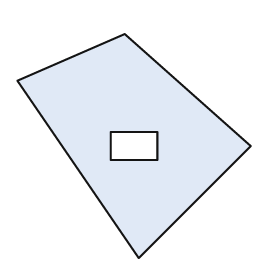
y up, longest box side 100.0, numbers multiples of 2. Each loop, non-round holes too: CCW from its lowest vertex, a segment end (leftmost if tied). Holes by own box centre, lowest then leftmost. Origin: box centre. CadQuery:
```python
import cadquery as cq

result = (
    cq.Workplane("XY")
    .moveTo(2.0, -48.0)
    .lineTo(50.0, 0.0)
    .lineTo(-4.0, 48.0)
    .lineTo(-50.0, 28.0)
    .close()
    .moveTo(-10.0, -6.0)
    .lineTo(10.0, -6.0)
    .lineTo(10.0, 6.0)
    .lineTo(-10.0, 6.0)
    .close()
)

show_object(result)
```